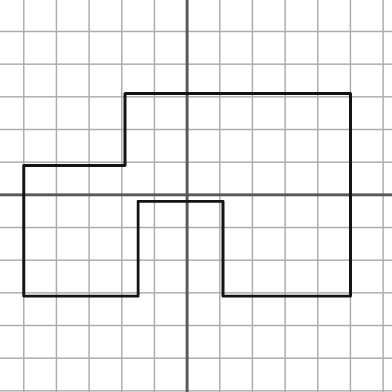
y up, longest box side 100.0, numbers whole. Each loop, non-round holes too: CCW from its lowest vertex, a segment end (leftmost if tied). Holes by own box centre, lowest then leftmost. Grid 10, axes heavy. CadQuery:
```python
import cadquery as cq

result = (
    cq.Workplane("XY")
    .moveTo(-50.0, -31.0)
    .lineTo(-15.0, -31.0)
    .lineTo(-15.0, -2.0)
    .lineTo(11.0, -2.0)
    .lineTo(11.0, -31.0)
    .lineTo(50.0, -31.0)
    .lineTo(50.0, 31.0)
    .lineTo(-19.0, 31.0)
    .lineTo(-19.0, 9.0)
    .lineTo(-50.0, 9.0)
    .close()
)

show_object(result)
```